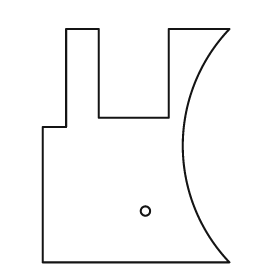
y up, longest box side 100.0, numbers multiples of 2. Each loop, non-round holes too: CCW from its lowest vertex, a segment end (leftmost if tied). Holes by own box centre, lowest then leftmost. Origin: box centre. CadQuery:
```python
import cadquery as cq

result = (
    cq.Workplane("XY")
    .moveTo(-40.0, -50.0)
    .lineTo(40.0, -50.0)
    .threePointArc((20.0, 0.0), (40.0, 50.0))
    .lineTo(14.0, 50.0)
    .lineTo(14.0, 12.0)
    .lineTo(-16.0, 12.0)
    .lineTo(-16.0, 50.0)
    .lineTo(-30.0, 50.0)
    .lineTo(-30.0, 8.0)
    .lineTo(-40.0, 8.0)
    .close()
    .moveTo(4.0, -28.0)
    .circle(2.0)
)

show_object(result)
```